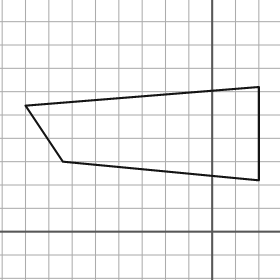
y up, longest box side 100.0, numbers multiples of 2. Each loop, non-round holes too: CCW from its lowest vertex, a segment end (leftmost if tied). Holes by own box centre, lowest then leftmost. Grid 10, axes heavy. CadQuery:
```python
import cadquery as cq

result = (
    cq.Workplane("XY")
    .moveTo(20.0, 22.0)
    .lineTo(20.0, 62.0)
    .lineTo(-80.0, 54.0)
    .lineTo(-64.0, 30.0)
    .close()
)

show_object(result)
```